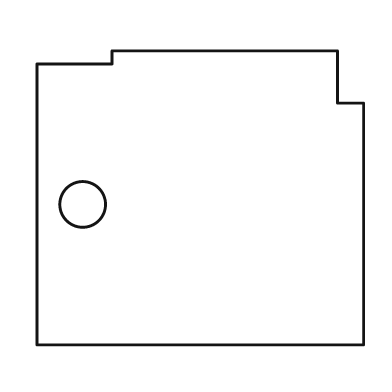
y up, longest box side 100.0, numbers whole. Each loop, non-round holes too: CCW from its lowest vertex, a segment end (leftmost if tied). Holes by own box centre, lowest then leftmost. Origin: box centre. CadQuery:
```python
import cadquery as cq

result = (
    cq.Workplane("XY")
    .moveTo(-50.0, -45.0)
    .lineTo(50.0, -45.0)
    .lineTo(50.0, 29.0)
    .lineTo(42.0, 29.0)
    .lineTo(42.0, 45.0)
    .lineTo(-27.0, 45.0)
    .lineTo(-27.0, 41.0)
    .lineTo(-50.0, 41.0)
    .close()
    .moveTo(-36.0, -2.0)
    .circle(7.0)
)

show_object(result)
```